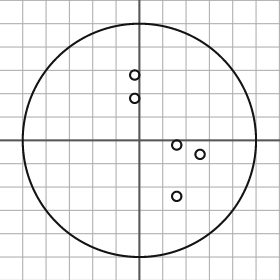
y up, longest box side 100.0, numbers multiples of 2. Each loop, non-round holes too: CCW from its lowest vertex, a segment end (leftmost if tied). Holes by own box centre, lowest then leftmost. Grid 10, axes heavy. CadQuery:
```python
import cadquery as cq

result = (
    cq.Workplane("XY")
    .moveTo(0.0, 0.0)
    .circle(50.0)
    .moveTo(16.0, -24.0)
    .circle(2.0)
    .moveTo(26.0, -6.0)
    .circle(2.0)
    .moveTo(16.0, -2.0)
    .circle(2.0)
    .moveTo(-2.0, 18.0)
    .circle(2.0)
    .moveTo(-2.0, 28.0)
    .circle(2.0)
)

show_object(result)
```